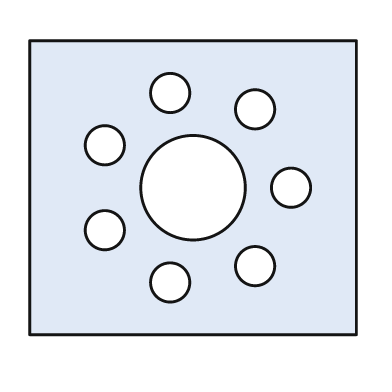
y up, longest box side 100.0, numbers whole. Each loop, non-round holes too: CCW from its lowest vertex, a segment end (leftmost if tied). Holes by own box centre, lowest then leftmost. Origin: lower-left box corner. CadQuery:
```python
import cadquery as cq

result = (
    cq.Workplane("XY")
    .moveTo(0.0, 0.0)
    .lineTo(100.0, 0.0)
    .lineTo(100.0, 90.0)
    .lineTo(0.0, 90.0)
    .close()
    .moveTo(43.0, 16.0)
    .circle(6.0)
    .moveTo(69.0, 21.0)
    .circle(6.0)
    .moveTo(23.0, 32.0)
    .circle(6.0)
    .moveTo(50.0, 45.0)
    .circle(16.0)
    .moveTo(80.0, 45.0)
    .circle(6.0)
    .moveTo(23.0, 58.0)
    .circle(6.0)
    .moveTo(69.0, 69.0)
    .circle(6.0)
    .moveTo(43.0, 74.0)
    .circle(6.0)
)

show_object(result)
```